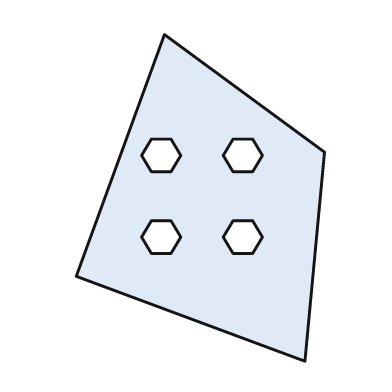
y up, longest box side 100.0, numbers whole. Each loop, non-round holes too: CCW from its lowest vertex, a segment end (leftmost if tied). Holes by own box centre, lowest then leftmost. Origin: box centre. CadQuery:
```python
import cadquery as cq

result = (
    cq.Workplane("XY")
    .moveTo(32.0, -50.0)
    .lineTo(38.0, 14.0)
    .lineTo(-11.0, 50.0)
    .lineTo(-38.0, -24.0)
    .close()
    .moveTo(-15.0, -17.0)
    .lineTo(-9.0, -17.0)
    .lineTo(-6.0, -12.0)
    .lineTo(-9.0, -7.0)
    .lineTo(-15.0, -7.0)
    .lineTo(-18.0, -12.0)
    .close()
    .moveTo(10.0, -17.0)
    .lineTo(16.0, -17.0)
    .lineTo(19.0, -12.0)
    .lineTo(16.0, -7.0)
    .lineTo(10.0, -7.0)
    .lineTo(7.0, -12.0)
    .close()
    .moveTo(-15.0, 8.0)
    .lineTo(-9.0, 8.0)
    .lineTo(-6.0, 13.0)
    .lineTo(-9.0, 18.0)
    .lineTo(-15.0, 18.0)
    .lineTo(-18.0, 13.0)
    .close()
    .moveTo(10.0, 8.0)
    .lineTo(16.0, 8.0)
    .lineTo(19.0, 13.0)
    .lineTo(16.0, 18.0)
    .lineTo(10.0, 18.0)
    .lineTo(7.0, 13.0)
    .close()
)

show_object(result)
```